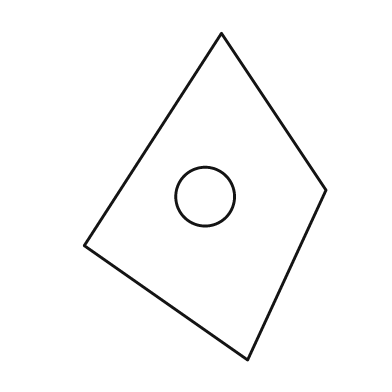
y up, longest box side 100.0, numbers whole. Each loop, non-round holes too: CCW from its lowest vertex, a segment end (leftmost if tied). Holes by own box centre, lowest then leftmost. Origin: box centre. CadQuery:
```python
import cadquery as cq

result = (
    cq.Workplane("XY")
    .moveTo(13.0, -50.0)
    .lineTo(37.0, 2.0)
    .lineTo(5.0, 50.0)
    .lineTo(-37.0, -15.0)
    .close()
    .moveTo(0.0, 0.0)
    .circle(9.0)
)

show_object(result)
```